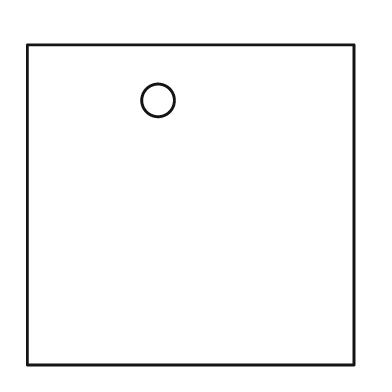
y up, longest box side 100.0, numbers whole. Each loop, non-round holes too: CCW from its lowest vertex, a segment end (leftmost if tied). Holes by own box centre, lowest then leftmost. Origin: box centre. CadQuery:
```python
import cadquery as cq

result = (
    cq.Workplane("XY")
    .moveTo(-50.0, -49.0)
    .lineTo(50.0, -49.0)
    .lineTo(50.0, 49.0)
    .lineTo(-50.0, 49.0)
    .close()
    .moveTo(-10.0, 32.0)
    .circle(5.0)
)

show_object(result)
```